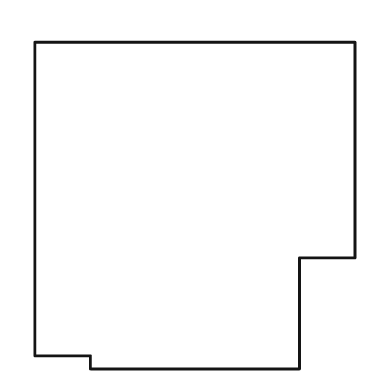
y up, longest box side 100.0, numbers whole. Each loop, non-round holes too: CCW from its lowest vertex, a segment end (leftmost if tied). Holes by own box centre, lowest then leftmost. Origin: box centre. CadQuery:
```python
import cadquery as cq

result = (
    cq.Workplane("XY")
    .moveTo(-32.0, -50.0)
    .lineTo(32.0, -50.0)
    .lineTo(32.0, -16.0)
    .lineTo(49.0, -16.0)
    .lineTo(49.0, 50.0)
    .lineTo(-49.0, 50.0)
    .lineTo(-49.0, -46.0)
    .lineTo(-32.0, -46.0)
    .close()
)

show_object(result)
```